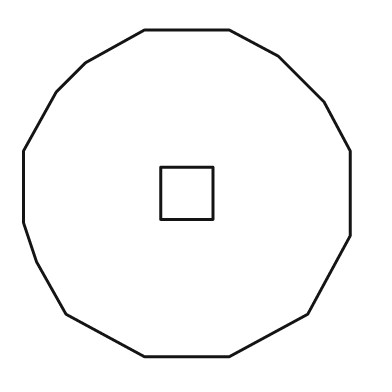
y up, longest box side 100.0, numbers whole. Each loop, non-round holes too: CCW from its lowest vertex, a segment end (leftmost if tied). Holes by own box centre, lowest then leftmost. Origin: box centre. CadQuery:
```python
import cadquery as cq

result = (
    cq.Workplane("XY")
    .moveTo(-13.0, -50.0)
    .lineTo(13.0, -50.0)
    .lineTo(37.0, -37.0)
    .lineTo(50.0, -13.0)
    .lineTo(50.0, 13.0)
    .lineTo(42.0, 28.0)
    .lineTo(28.0, 42.0)
    .lineTo(13.0, 50.0)
    .lineTo(-13.0, 50.0)
    .lineTo(-31.0, 40.0)
    .lineTo(-40.0, 31.0)
    .lineTo(-50.0, 13.0)
    .lineTo(-50.0, -9.0)
    .lineTo(-46.0, -21.0)
    .lineTo(-37.0, -37.0)
    .close()
    .moveTo(-8.0, -8.0)
    .lineTo(8.0, -8.0)
    .lineTo(8.0, 8.0)
    .lineTo(-8.0, 8.0)
    .close()
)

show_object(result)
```